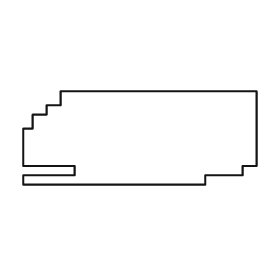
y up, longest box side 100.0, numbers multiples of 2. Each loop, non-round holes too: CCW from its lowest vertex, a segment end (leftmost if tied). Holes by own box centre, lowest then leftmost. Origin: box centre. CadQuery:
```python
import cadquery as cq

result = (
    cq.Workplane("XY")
    .moveTo(-50.0, -20.0)
    .lineTo(28.0, -20.0)
    .lineTo(28.0, -16.0)
    .lineTo(44.0, -16.0)
    .lineTo(44.0, -12.0)
    .lineTo(50.0, -12.0)
    .lineTo(50.0, 20.0)
    .lineTo(-34.0, 20.0)
    .lineTo(-34.0, 14.0)
    .lineTo(-40.0, 14.0)
    .lineTo(-40.0, 10.0)
    .lineTo(-46.0, 10.0)
    .lineTo(-46.0, 4.0)
    .lineTo(-50.0, 4.0)
    .lineTo(-50.0, -12.0)
    .lineTo(-28.0, -12.0)
    .lineTo(-28.0, -16.0)
    .lineTo(-50.0, -16.0)
    .close()
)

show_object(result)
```